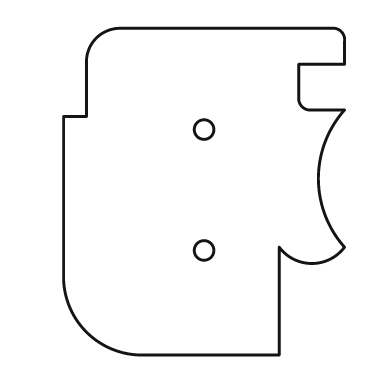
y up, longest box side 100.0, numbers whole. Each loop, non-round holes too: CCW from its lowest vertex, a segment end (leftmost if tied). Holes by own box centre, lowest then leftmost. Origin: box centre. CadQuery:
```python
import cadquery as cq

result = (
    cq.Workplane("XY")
    .moveTo(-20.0, -50.0)
    .lineTo(23.0, -50.0)
    .lineTo(23.0, -17.0)
    .threePointArc((33.0, -22.0), (43.0, -17.0))
    .threePointArc((35.0, 4.0), (43.0, 25.0))
    .lineTo(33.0, 25.0)
    .threePointArc((30.0, 26.0), (29.0, 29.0))
    .lineTo(29.0, 39.0)
    .lineTo(43.0, 39.0)
    .lineTo(43.0, 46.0)
    .threePointArc((42.0, 49.0), (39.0, 50.0))
    .lineTo(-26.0, 50.0)
    .threePointArc((-33.0, 47.0), (-36.0, 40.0))
    .lineTo(-36.0, 23.0)
    .lineTo(-43.0, 23.0)
    .lineTo(-43.0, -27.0)
    .threePointArc((-36.0, -43.0), (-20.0, -50.0))
    .close()
    .moveTo(0.0, -18.0)
    .circle(3.0)
    .moveTo(0.0, 19.0)
    .circle(3.0)
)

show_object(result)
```